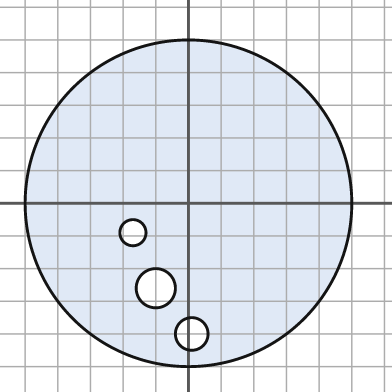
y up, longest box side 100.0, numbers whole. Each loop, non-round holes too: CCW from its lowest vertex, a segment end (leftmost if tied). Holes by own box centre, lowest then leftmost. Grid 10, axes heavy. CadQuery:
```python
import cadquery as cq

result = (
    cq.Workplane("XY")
    .moveTo(0.0, 0.0)
    .circle(50.0)
    .moveTo(1.0, -40.0)
    .circle(5.0)
    .moveTo(-10.0, -26.0)
    .circle(6.0)
    .moveTo(-17.0, -9.0)
    .circle(4.0)
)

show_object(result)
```